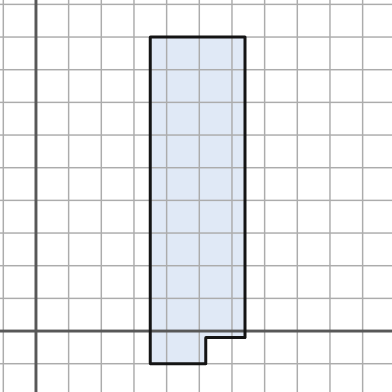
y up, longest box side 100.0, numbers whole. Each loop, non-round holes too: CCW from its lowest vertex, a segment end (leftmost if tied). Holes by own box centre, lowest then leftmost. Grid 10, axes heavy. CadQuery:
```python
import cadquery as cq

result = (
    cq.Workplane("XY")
    .moveTo(35.0, -10.0)
    .lineTo(52.0, -10.0)
    .lineTo(52.0, -2.0)
    .lineTo(64.0, -2.0)
    .lineTo(64.0, 90.0)
    .lineTo(35.0, 90.0)
    .close()
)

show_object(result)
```